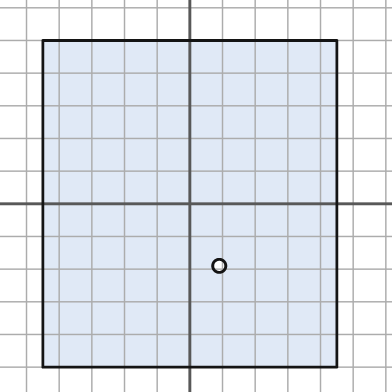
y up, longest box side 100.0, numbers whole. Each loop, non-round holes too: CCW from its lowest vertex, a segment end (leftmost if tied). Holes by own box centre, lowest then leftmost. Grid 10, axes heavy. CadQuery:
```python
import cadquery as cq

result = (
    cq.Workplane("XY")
    .moveTo(-45.0, -50.0)
    .lineTo(45.0, -50.0)
    .lineTo(45.0, 50.0)
    .lineTo(-45.0, 50.0)
    .close()
    .moveTo(9.0, -19.0)
    .circle(2.0)
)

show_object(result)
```